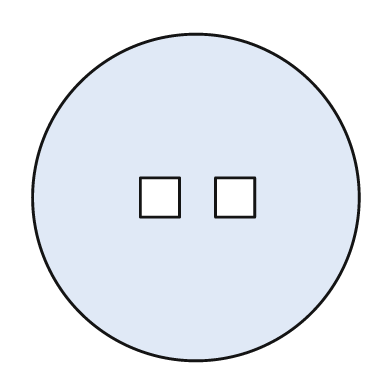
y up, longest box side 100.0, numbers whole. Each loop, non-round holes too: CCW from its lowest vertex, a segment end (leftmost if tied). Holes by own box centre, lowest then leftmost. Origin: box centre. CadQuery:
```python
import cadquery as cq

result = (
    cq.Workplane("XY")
    .moveTo(0.0, 0.0)
    .circle(50.0)
    .moveTo(-17.0, -6.0)
    .lineTo(-5.0, -6.0)
    .lineTo(-5.0, 6.0)
    .lineTo(-17.0, 6.0)
    .close()
    .moveTo(6.0, -6.0)
    .lineTo(18.0, -6.0)
    .lineTo(18.0, 6.0)
    .lineTo(6.0, 6.0)
    .close()
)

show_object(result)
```